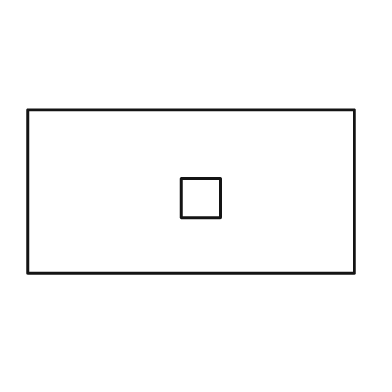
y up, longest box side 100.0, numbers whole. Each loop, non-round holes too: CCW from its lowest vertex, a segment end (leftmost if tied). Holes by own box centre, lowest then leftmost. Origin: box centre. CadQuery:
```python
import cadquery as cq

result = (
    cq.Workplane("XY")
    .moveTo(-50.0, -25.0)
    .lineTo(50.0, -25.0)
    .lineTo(50.0, 25.0)
    .lineTo(-50.0, 25.0)
    .close()
    .moveTo(-3.0, -8.0)
    .lineTo(9.0, -8.0)
    .lineTo(9.0, 4.0)
    .lineTo(-3.0, 4.0)
    .close()
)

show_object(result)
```